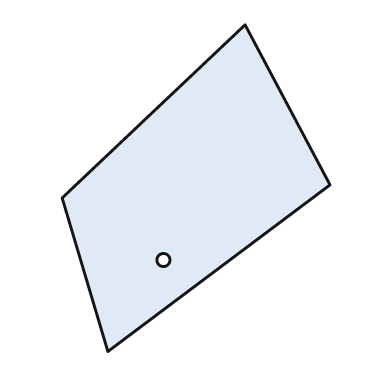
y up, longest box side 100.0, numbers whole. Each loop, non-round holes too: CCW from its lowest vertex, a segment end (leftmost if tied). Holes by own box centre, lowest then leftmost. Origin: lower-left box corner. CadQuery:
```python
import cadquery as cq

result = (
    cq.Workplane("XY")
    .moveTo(14.0, 0.0)
    .lineTo(82.0, 51.0)
    .lineTo(56.0, 100.0)
    .lineTo(0.0, 47.0)
    .close()
    .moveTo(31.0, 28.0)
    .circle(2.0)
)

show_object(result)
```